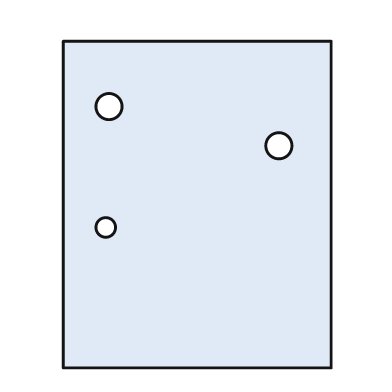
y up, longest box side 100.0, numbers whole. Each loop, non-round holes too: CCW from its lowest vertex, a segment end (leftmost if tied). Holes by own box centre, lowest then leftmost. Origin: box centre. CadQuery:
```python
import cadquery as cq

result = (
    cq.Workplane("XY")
    .moveTo(-41.0, -50.0)
    .lineTo(41.0, -50.0)
    .lineTo(41.0, 50.0)
    .lineTo(-41.0, 50.0)
    .close()
    .moveTo(-28.0, -7.0)
    .circle(3.0)
    .moveTo(25.0, 18.0)
    .circle(4.0)
    .moveTo(-27.0, 30.0)
    .circle(4.0)
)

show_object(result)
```